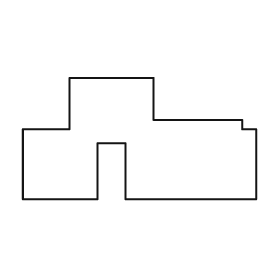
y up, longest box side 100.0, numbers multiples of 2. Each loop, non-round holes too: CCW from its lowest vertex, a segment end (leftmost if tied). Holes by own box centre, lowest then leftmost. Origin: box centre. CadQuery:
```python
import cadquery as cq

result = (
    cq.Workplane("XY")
    .moveTo(-50.0, -26.0)
    .lineTo(-18.0, -26.0)
    .lineTo(-18.0, -2.0)
    .lineTo(-6.0, -2.0)
    .lineTo(-6.0, -26.0)
    .lineTo(50.0, -26.0)
    .lineTo(50.0, 4.0)
    .lineTo(44.0, 4.0)
    .lineTo(44.0, 8.0)
    .lineTo(6.0, 8.0)
    .lineTo(6.0, 26.0)
    .lineTo(-30.0, 26.0)
    .lineTo(-30.0, 4.0)
    .lineTo(-50.0, 4.0)
    .close()
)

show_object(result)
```